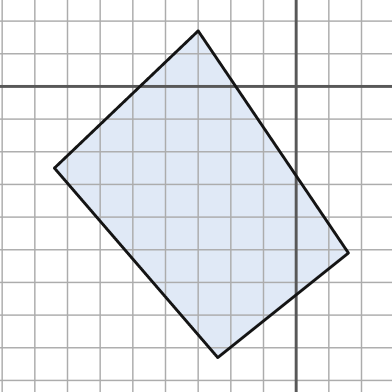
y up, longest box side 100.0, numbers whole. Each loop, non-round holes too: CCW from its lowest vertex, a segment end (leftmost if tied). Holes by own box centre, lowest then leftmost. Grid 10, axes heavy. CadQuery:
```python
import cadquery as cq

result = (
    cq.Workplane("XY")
    .moveTo(-24.0, -83.0)
    .lineTo(16.0, -51.0)
    .lineTo(-30.0, 17.0)
    .lineTo(-74.0, -25.0)
    .close()
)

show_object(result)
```